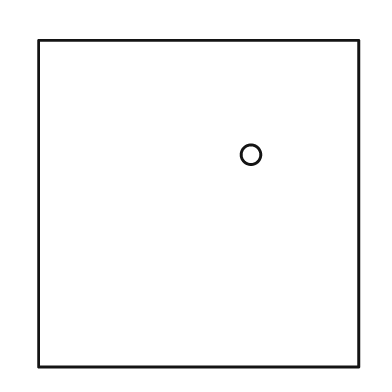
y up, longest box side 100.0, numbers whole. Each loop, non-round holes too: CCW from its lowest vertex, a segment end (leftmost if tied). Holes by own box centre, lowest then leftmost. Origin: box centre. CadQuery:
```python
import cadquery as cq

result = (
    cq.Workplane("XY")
    .moveTo(-49.0, -50.0)
    .lineTo(49.0, -50.0)
    .lineTo(49.0, 50.0)
    .lineTo(-49.0, 50.0)
    .close()
    .moveTo(16.0, 15.0)
    .circle(3.0)
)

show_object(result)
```